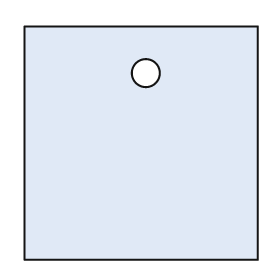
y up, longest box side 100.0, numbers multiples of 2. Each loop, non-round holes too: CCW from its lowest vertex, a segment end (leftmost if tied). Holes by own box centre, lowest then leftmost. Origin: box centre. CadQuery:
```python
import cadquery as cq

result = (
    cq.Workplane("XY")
    .moveTo(-50.0, -50.0)
    .lineTo(50.0, -50.0)
    .lineTo(50.0, 50.0)
    .lineTo(-50.0, 50.0)
    .close()
    .moveTo(2.0, 30.0)
    .circle(6.0)
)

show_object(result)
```